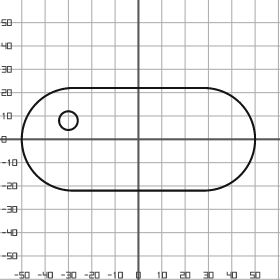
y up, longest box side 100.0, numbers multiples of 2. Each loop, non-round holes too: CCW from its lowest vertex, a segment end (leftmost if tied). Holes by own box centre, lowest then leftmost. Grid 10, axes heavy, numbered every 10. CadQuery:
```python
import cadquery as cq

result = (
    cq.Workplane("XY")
    .moveTo(-28.0, -22.0)
    .lineTo(28.0, -22.0)
    .threePointArc((50.0, 0.0), (28.0, 22.0))
    .lineTo(-28.0, 22.0)
    .threePointArc((-50.0, 0.0), (-28.0, -22.0))
    .close()
    .moveTo(-30.0, 8.0)
    .circle(4.0)
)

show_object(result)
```